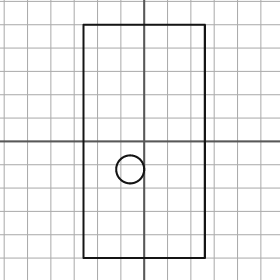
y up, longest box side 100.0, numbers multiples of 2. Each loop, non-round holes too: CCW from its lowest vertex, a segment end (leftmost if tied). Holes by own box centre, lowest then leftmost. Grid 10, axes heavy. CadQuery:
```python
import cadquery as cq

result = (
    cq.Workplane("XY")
    .moveTo(-26.0, -50.0)
    .lineTo(26.0, -50.0)
    .lineTo(26.0, 50.0)
    .lineTo(-26.0, 50.0)
    .close()
    .moveTo(-6.0, -12.0)
    .circle(6.0)
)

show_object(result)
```